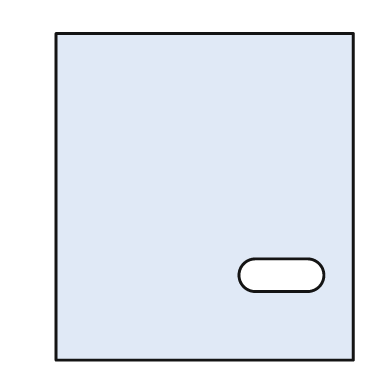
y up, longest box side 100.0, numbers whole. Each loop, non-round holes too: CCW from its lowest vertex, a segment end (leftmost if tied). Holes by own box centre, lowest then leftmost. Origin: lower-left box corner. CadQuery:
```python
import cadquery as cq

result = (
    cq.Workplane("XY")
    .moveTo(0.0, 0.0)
    .lineTo(91.0, 0.0)
    .lineTo(91.0, 100.0)
    .lineTo(0.0, 100.0)
    .close()
    .moveTo(61.0, 21.0)
    .lineTo(77.0, 21.0)
    .threePointArc((82.0, 26.0), (77.0, 31.0))
    .lineTo(61.0, 31.0)
    .threePointArc((56.0, 26.0), (61.0, 21.0))
    .close()
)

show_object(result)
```